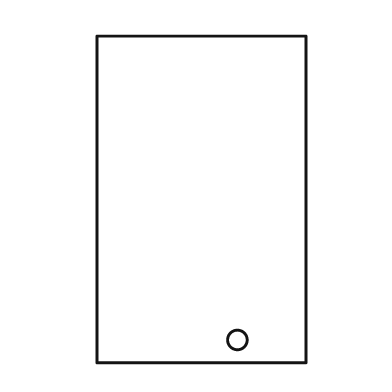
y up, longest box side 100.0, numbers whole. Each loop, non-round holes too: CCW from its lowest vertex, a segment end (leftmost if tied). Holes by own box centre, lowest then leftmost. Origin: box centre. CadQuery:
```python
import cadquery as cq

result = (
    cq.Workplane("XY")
    .moveTo(-32.0, -50.0)
    .lineTo(32.0, -50.0)
    .lineTo(32.0, 50.0)
    .lineTo(-32.0, 50.0)
    .close()
    .moveTo(11.0, -43.0)
    .circle(3.0)
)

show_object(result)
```